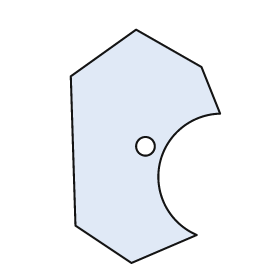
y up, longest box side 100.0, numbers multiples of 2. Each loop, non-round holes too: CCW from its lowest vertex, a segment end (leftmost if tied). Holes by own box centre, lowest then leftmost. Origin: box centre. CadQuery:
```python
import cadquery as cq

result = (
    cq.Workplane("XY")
    .moveTo(-6.0, -50.0)
    .lineTo(22.0, -38.0)
    .threePointArc((6.0, -8.0), (32.0, 14.0))
    .lineTo(24.0, 34.0)
    .lineTo(-4.0, 50.0)
    .lineTo(-32.0, 30.0)
    .lineTo(-30.0, -34.0)
    .close()
    .moveTo(0.0, 0.0)
    .circle(4.0)
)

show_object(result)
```